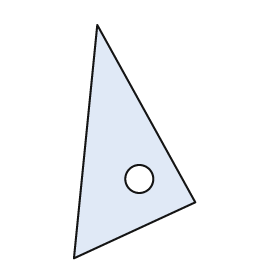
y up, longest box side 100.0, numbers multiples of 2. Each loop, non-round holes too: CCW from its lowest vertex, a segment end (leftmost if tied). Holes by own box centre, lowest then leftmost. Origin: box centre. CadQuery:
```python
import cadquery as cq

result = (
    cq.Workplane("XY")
    .moveTo(-26.0, -50.0)
    .lineTo(26.0, -26.0)
    .lineTo(-16.0, 50.0)
    .close()
    .moveTo(2.0, -16.0)
    .circle(6.0)
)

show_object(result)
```